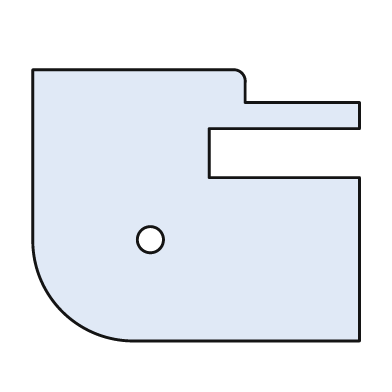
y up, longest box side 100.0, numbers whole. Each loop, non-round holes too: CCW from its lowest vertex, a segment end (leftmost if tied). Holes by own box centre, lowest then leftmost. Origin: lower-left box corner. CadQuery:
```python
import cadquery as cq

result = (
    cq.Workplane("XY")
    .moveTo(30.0, 0.0)
    .lineTo(100.0, 0.0)
    .lineTo(100.0, 50.0)
    .lineTo(54.0, 50.0)
    .lineTo(54.0, 65.0)
    .lineTo(100.0, 65.0)
    .lineTo(100.0, 73.0)
    .lineTo(65.0, 73.0)
    .lineTo(65.0, 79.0)
    .threePointArc((64.0, 82.0), (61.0, 83.0))
    .lineTo(0.0, 83.0)
    .lineTo(0.0, 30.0)
    .threePointArc((9.0, 9.0), (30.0, 0.0))
    .close()
    .moveTo(36.0, 31.0)
    .circle(4.0)
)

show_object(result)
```